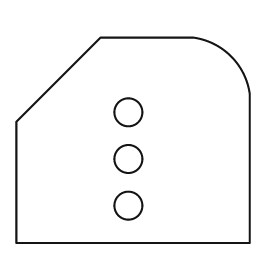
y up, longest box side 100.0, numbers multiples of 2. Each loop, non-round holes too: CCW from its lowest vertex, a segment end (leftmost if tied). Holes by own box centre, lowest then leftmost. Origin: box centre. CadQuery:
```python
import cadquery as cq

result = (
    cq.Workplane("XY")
    .moveTo(-50.0, -44.0)
    .lineTo(50.0, -44.0)
    .lineTo(50.0, 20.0)
    .threePointArc((42.0, 36.0), (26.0, 44.0))
    .lineTo(-14.0, 44.0)
    .lineTo(-50.0, 8.0)
    .close()
    .moveTo(-2.0, -28.0)
    .circle(6.0)
    .moveTo(-2.0, -8.0)
    .circle(6.0)
    .moveTo(-2.0, 12.0)
    .circle(6.0)
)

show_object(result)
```